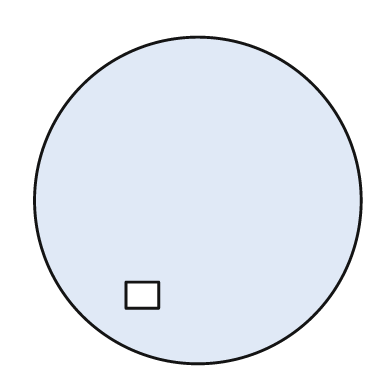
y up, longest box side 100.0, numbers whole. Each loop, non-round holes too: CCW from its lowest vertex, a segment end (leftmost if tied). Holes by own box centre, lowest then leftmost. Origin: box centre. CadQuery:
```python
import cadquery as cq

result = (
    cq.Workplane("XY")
    .moveTo(0.0, 0.0)
    .circle(50.0)
    .moveTo(-22.0, -33.0)
    .lineTo(-12.0, -33.0)
    .lineTo(-12.0, -25.0)
    .lineTo(-22.0, -25.0)
    .close()
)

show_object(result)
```